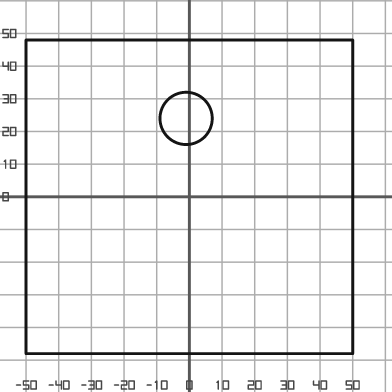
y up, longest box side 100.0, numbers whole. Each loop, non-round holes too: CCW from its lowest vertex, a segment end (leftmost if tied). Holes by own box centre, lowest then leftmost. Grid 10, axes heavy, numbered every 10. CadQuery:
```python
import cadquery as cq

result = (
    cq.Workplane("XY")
    .moveTo(-50.0, -48.0)
    .lineTo(50.0, -48.0)
    .lineTo(50.0, 48.0)
    .lineTo(-50.0, 48.0)
    .close()
    .moveTo(-1.0, 24.0)
    .circle(8.0)
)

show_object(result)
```